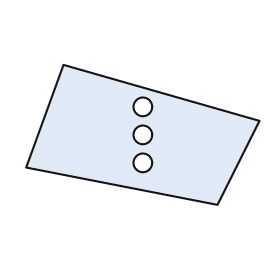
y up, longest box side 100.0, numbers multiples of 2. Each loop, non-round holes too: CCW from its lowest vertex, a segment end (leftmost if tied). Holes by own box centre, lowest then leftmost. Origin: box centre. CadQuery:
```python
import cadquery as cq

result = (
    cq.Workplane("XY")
    .moveTo(32.0, -30.0)
    .lineTo(50.0, 6.0)
    .lineTo(-34.0, 30.0)
    .lineTo(-50.0, -14.0)
    .close()
    .moveTo(0.0, -12.0)
    .circle(4.0)
    .moveTo(0.0, 0.0)
    .circle(4.0)
    .moveTo(0.0, 12.0)
    .circle(4.0)
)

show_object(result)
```